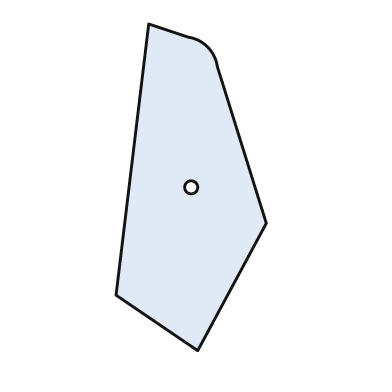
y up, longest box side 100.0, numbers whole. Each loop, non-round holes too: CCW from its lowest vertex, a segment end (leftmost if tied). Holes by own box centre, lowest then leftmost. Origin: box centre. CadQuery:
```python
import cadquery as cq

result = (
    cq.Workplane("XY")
    .moveTo(2.0, -50.0)
    .lineTo(23.0, -11.0)
    .lineTo(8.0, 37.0)
    .threePointArc((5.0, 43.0), (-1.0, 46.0))
    .lineTo(-13.0, 50.0)
    .lineTo(-23.0, -33.0)
    .close()
    .moveTo(0.0, 0.0)
    .circle(2.0)
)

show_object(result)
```